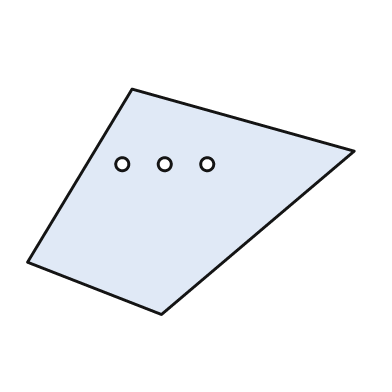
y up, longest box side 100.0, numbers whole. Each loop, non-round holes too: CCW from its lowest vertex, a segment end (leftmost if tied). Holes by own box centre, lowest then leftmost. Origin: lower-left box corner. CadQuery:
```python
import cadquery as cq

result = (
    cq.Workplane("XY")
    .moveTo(41.0, 0.0)
    .lineTo(100.0, 50.0)
    .lineTo(32.0, 69.0)
    .lineTo(0.0, 16.0)
    .close()
    .moveTo(29.0, 46.0)
    .circle(2.0)
    .moveTo(42.0, 46.0)
    .circle(2.0)
    .moveTo(55.0, 46.0)
    .circle(2.0)
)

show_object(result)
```